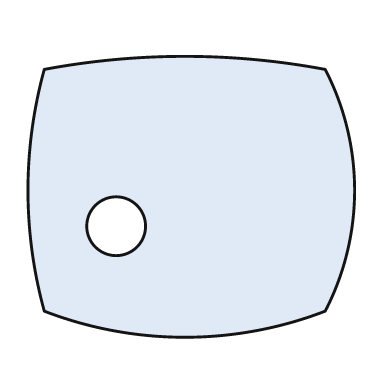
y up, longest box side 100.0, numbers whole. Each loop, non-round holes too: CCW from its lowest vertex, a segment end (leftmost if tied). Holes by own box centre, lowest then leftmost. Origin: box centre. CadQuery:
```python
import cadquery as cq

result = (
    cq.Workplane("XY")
    .moveTo(-45.0, -35.0)
    .threePointArc((-2.0, -43.0), (41.0, -35.0))
    .threePointArc((50.0, 2.0), (41.0, 39.0))
    .threePointArc((-2.0, 43.0), (-45.0, 39.0))
    .threePointArc((-50.0, 2.0), (-45.0, -35.0))
    .close()
    .moveTo(-23.0, -9.0)
    .circle(9.0)
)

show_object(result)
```